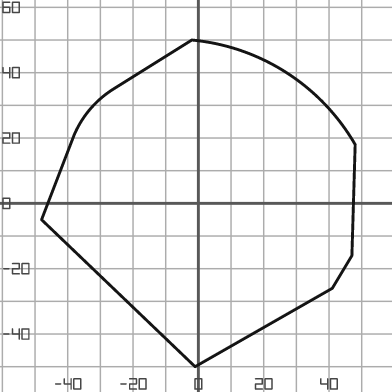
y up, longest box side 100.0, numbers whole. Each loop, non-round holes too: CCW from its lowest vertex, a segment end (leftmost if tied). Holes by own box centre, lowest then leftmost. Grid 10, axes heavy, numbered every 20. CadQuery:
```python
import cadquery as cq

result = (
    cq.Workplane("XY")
    .moveTo(-1.0, -50.0)
    .lineTo(41.0, -26.0)
    .lineTo(47.0, -16.0)
    .lineTo(48.0, 18.0)
    .threePointArc((27.0, 40.0), (-2.0, 50.0))
    .lineTo(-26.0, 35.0)
    .threePointArc((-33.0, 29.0), (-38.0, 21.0))
    .lineTo(-48.0, -5.0)
    .close()
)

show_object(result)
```